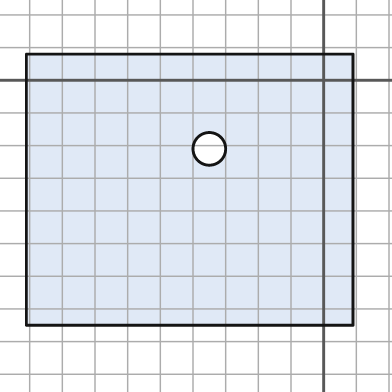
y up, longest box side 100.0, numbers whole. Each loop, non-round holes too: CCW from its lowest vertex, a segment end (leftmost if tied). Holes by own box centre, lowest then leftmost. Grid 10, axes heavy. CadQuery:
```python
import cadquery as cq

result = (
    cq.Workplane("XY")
    .moveTo(-91.0, -75.0)
    .lineTo(9.0, -75.0)
    .lineTo(9.0, 8.0)
    .lineTo(-91.0, 8.0)
    .close()
    .moveTo(-35.0, -21.0)
    .circle(5.0)
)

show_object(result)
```